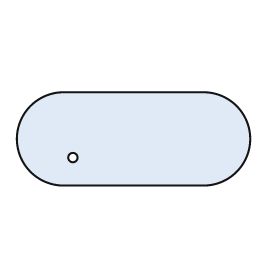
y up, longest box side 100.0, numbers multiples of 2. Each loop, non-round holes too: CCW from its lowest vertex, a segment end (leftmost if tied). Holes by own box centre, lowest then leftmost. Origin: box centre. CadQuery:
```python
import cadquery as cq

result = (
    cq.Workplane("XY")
    .moveTo(-30.0, -20.0)
    .lineTo(30.0, -20.0)
    .threePointArc((50.0, 0.0), (30.0, 20.0))
    .lineTo(-30.0, 20.0)
    .threePointArc((-50.0, 0.0), (-30.0, -20.0))
    .close()
    .moveTo(-26.0, -8.0)
    .circle(2.0)
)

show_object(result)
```